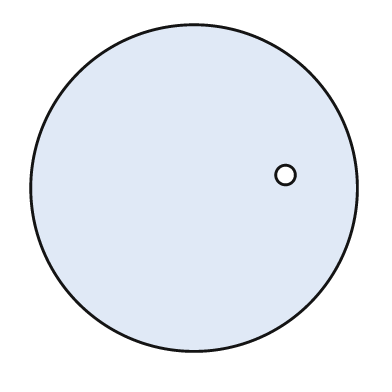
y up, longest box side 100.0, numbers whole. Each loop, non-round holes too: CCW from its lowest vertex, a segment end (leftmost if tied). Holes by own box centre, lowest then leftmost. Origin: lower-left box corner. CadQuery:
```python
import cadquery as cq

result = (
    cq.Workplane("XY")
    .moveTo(50.0, 50.0)
    .circle(50.0)
    .moveTo(78.0, 54.0)
    .circle(3.0)
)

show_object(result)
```